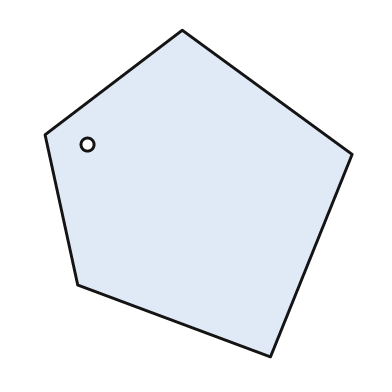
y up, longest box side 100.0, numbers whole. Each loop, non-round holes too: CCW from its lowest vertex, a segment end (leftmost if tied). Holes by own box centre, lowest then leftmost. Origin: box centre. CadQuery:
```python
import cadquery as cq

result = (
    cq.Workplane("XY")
    .moveTo(22.0, -50.0)
    .lineTo(47.0, 12.0)
    .lineTo(-5.0, 50.0)
    .lineTo(-47.0, 18.0)
    .lineTo(-37.0, -28.0)
    .close()
    .moveTo(-34.0, 15.0)
    .circle(2.0)
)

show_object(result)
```